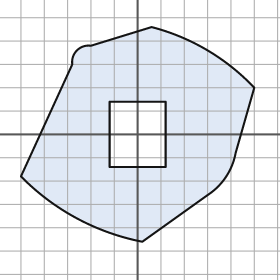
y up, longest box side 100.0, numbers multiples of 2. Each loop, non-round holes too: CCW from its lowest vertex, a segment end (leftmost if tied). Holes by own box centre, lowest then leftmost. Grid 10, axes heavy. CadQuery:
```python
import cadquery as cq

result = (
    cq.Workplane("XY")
    .moveTo(2.0, -46.0)
    .lineTo(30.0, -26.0)
    .threePointArc((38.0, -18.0), (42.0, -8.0))
    .lineTo(50.0, 20.0)
    .threePointArc((30.0, 36.0), (6.0, 46.0))
    .lineTo(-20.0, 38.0)
    .threePointArc((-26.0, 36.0), (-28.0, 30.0))
    .lineTo(-50.0, -18.0)
    .threePointArc((-26.0, -36.0), (2.0, -46.0))
    .close()
    .moveTo(-12.0, -14.0)
    .lineTo(12.0, -14.0)
    .lineTo(12.0, 14.0)
    .lineTo(-12.0, 14.0)
    .close()
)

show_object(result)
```